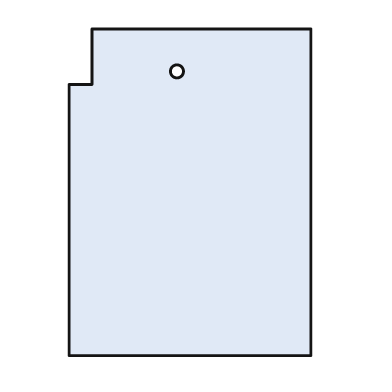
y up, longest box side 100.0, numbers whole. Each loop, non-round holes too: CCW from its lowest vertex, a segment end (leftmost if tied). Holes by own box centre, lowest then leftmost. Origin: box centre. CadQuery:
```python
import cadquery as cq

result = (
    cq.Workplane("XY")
    .moveTo(-37.0, -50.0)
    .lineTo(37.0, -50.0)
    .lineTo(37.0, 50.0)
    .lineTo(-30.0, 50.0)
    .lineTo(-30.0, 33.0)
    .lineTo(-37.0, 33.0)
    .close()
    .moveTo(-4.0, 37.0)
    .circle(2.0)
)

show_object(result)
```